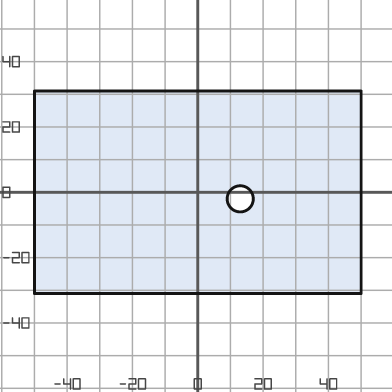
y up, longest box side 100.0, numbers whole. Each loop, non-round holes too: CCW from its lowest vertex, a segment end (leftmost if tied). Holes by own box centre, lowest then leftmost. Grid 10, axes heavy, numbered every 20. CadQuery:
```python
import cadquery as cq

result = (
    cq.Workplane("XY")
    .moveTo(-50.0, -31.0)
    .lineTo(50.0, -31.0)
    .lineTo(50.0, 31.0)
    .lineTo(-50.0, 31.0)
    .close()
    .moveTo(13.0, -2.0)
    .circle(4.0)
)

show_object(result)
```